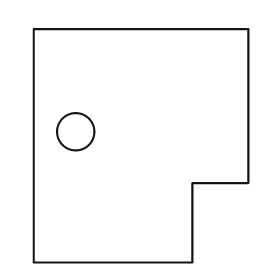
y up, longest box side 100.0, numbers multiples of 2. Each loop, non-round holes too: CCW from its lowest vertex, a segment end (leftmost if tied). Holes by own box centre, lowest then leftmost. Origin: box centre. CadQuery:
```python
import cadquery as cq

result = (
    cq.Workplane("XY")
    .moveTo(-46.0, -50.0)
    .lineTo(22.0, -50.0)
    .lineTo(22.0, -16.0)
    .lineTo(46.0, -16.0)
    .lineTo(46.0, 50.0)
    .lineTo(-46.0, 50.0)
    .close()
    .moveTo(-28.0, 6.0)
    .circle(8.0)
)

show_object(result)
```